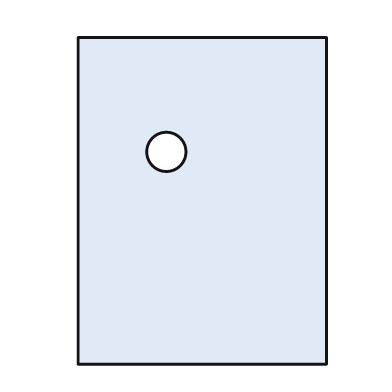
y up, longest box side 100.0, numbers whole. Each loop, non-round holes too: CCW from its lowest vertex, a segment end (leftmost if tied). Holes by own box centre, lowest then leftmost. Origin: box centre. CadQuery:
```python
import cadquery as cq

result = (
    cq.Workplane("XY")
    .moveTo(-38.0, -50.0)
    .lineTo(38.0, -50.0)
    .lineTo(38.0, 50.0)
    .lineTo(-38.0, 50.0)
    .close()
    .moveTo(-11.0, 15.0)
    .circle(6.0)
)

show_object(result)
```